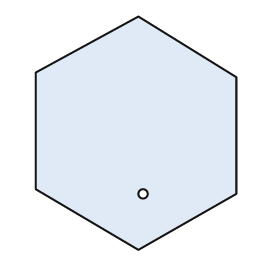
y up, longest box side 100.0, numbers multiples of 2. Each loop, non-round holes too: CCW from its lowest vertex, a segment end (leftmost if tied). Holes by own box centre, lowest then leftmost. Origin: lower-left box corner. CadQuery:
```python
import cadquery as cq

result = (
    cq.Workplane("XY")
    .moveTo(44.0, 0.0)
    .lineTo(86.0, 24.0)
    .lineTo(86.0, 74.0)
    .lineTo(44.0, 100.0)
    .lineTo(0.0, 76.0)
    .lineTo(0.0, 26.0)
    .close()
    .moveTo(46.0, 24.0)
    .circle(2.0)
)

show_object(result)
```